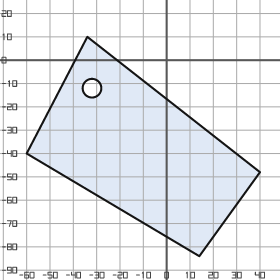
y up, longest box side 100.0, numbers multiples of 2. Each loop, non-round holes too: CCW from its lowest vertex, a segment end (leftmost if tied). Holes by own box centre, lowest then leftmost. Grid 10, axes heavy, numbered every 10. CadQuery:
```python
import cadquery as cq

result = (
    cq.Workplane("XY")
    .moveTo(14.0, -84.0)
    .lineTo(40.0, -48.0)
    .lineTo(-34.0, 10.0)
    .lineTo(-60.0, -40.0)
    .close()
    .moveTo(-32.0, -12.0)
    .circle(4.0)
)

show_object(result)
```